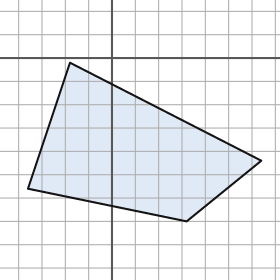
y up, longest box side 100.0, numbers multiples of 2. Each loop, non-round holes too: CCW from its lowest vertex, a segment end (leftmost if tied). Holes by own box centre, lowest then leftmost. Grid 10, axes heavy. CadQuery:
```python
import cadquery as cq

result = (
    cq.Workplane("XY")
    .moveTo(32.0, -70.0)
    .lineTo(64.0, -44.0)
    .lineTo(-18.0, -2.0)
    .lineTo(-36.0, -56.0)
    .close()
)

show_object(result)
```